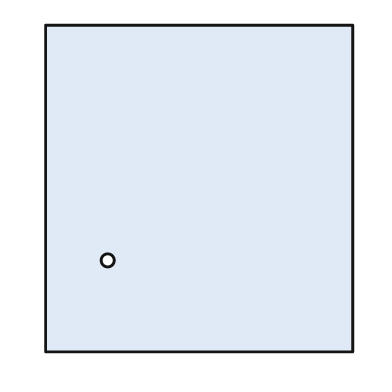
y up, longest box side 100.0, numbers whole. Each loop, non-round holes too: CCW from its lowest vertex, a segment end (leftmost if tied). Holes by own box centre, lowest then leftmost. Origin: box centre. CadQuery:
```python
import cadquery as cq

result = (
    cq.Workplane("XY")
    .moveTo(-47.0, -50.0)
    .lineTo(47.0, -50.0)
    .lineTo(47.0, 50.0)
    .lineTo(-47.0, 50.0)
    .close()
    .moveTo(-28.0, -22.0)
    .circle(2.0)
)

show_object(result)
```